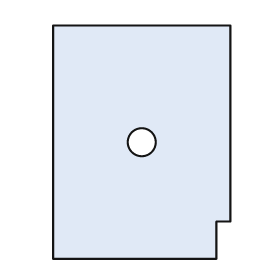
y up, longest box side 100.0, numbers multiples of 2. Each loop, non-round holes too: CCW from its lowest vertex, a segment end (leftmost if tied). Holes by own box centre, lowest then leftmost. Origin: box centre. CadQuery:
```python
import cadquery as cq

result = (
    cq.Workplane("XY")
    .moveTo(-38.0, -50.0)
    .lineTo(32.0, -50.0)
    .lineTo(32.0, -34.0)
    .lineTo(38.0, -34.0)
    .lineTo(38.0, 50.0)
    .lineTo(-38.0, 50.0)
    .close()
    .moveTo(0.0, 0.0)
    .circle(6.0)
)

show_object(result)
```